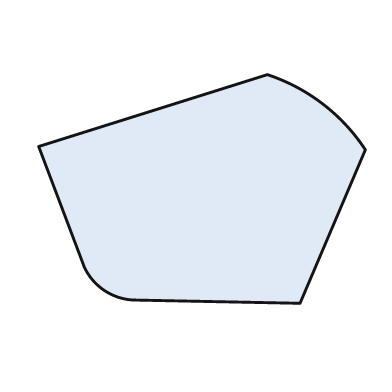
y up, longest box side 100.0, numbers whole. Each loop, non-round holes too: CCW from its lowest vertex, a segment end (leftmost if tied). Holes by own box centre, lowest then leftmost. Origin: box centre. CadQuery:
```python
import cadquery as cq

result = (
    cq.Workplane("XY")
    .moveTo(30.0, -35.0)
    .lineTo(50.0, 12.0)
    .threePointArc((37.0, 26.0), (20.0, 35.0))
    .lineTo(-50.0, 13.0)
    .lineTo(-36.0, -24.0)
    .threePointArc((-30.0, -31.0), (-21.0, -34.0))
    .close()
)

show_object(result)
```